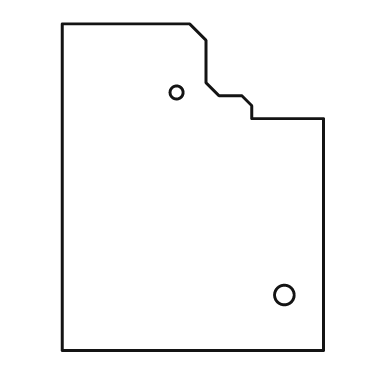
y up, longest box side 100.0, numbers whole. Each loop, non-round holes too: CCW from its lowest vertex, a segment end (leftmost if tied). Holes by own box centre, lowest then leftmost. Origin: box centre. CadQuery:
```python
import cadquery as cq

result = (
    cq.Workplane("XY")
    .moveTo(-40.0, -50.0)
    .lineTo(40.0, -50.0)
    .lineTo(40.0, 21.0)
    .lineTo(18.0, 21.0)
    .lineTo(18.0, 25.0)
    .lineTo(15.0, 28.0)
    .lineTo(8.0, 28.0)
    .lineTo(4.0, 32.0)
    .lineTo(4.0, 45.0)
    .lineTo(-1.0, 50.0)
    .lineTo(-40.0, 50.0)
    .close()
    .moveTo(28.0, -33.0)
    .circle(3.0)
    .moveTo(-5.0, 29.0)
    .circle(2.0)
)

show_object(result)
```